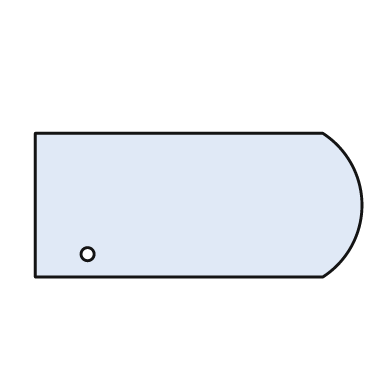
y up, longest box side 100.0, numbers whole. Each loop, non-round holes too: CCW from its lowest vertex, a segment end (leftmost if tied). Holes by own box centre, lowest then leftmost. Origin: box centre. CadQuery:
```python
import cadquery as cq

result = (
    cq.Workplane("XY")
    .moveTo(-50.0, -22.0)
    .lineTo(38.0, -22.0)
    .threePointArc((50.0, 0.0), (38.0, 22.0))
    .lineTo(-50.0, 22.0)
    .close()
    .moveTo(-34.0, -15.0)
    .circle(2.0)
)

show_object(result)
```